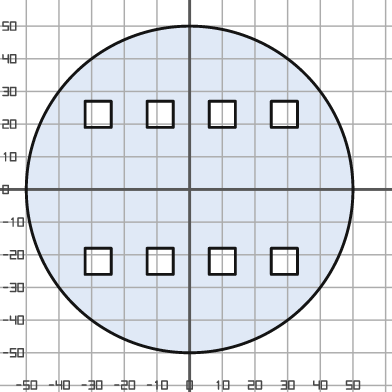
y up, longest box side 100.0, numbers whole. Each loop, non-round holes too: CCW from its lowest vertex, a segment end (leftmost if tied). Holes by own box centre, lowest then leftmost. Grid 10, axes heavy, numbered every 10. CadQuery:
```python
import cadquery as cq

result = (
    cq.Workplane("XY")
    .moveTo(0.0, 0.0)
    .circle(50.0)
    .moveTo(-32.0, -26.0)
    .lineTo(-24.0, -26.0)
    .lineTo(-24.0, -18.0)
    .lineTo(-32.0, -18.0)
    .close()
    .moveTo(-13.0, -26.0)
    .lineTo(-5.0, -26.0)
    .lineTo(-5.0, -18.0)
    .lineTo(-13.0, -18.0)
    .close()
    .moveTo(6.0, -26.0)
    .lineTo(14.0, -26.0)
    .lineTo(14.0, -18.0)
    .lineTo(6.0, -18.0)
    .close()
    .moveTo(25.0, -26.0)
    .lineTo(33.0, -26.0)
    .lineTo(33.0, -18.0)
    .lineTo(25.0, -18.0)
    .close()
    .moveTo(-32.0, 19.0)
    .lineTo(-24.0, 19.0)
    .lineTo(-24.0, 27.0)
    .lineTo(-32.0, 27.0)
    .close()
    .moveTo(-13.0, 19.0)
    .lineTo(-5.0, 19.0)
    .lineTo(-5.0, 27.0)
    .lineTo(-13.0, 27.0)
    .close()
    .moveTo(6.0, 19.0)
    .lineTo(14.0, 19.0)
    .lineTo(14.0, 27.0)
    .lineTo(6.0, 27.0)
    .close()
    .moveTo(25.0, 19.0)
    .lineTo(33.0, 19.0)
    .lineTo(33.0, 27.0)
    .lineTo(25.0, 27.0)
    .close()
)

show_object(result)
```